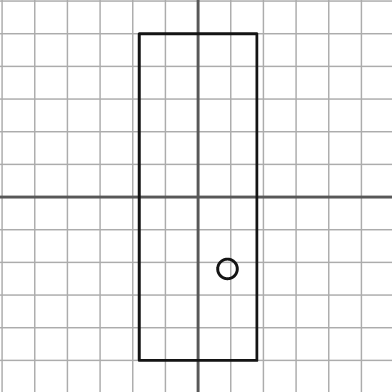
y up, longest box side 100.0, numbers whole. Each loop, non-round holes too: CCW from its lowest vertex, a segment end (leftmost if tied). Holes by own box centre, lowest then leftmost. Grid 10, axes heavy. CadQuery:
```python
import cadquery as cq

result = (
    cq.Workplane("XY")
    .moveTo(-18.0, -50.0)
    .lineTo(18.0, -50.0)
    .lineTo(18.0, 50.0)
    .lineTo(-18.0, 50.0)
    .close()
    .moveTo(9.0, -22.0)
    .circle(3.0)
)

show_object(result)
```